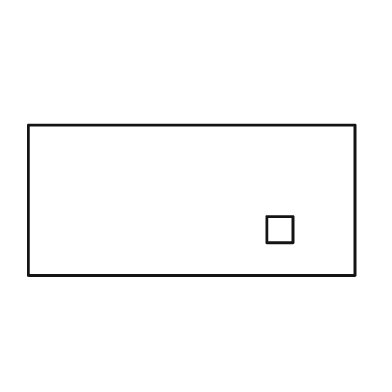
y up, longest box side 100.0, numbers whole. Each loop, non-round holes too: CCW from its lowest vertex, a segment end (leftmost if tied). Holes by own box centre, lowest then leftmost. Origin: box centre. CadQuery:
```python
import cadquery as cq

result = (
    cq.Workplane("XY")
    .moveTo(-50.0, -23.0)
    .lineTo(50.0, -23.0)
    .lineTo(50.0, 23.0)
    .lineTo(-50.0, 23.0)
    .close()
    .moveTo(23.0, -13.0)
    .lineTo(31.0, -13.0)
    .lineTo(31.0, -5.0)
    .lineTo(23.0, -5.0)
    .close()
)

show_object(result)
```